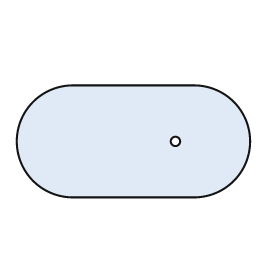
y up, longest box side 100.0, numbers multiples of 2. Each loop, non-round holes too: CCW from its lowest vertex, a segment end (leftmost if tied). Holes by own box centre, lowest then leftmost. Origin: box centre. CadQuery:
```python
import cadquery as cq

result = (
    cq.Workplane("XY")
    .moveTo(-26.0, -24.0)
    .lineTo(26.0, -24.0)
    .threePointArc((50.0, 0.0), (26.0, 24.0))
    .lineTo(-26.0, 24.0)
    .threePointArc((-50.0, 0.0), (-26.0, -24.0))
    .close()
    .moveTo(18.0, 0.0)
    .circle(2.0)
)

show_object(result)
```